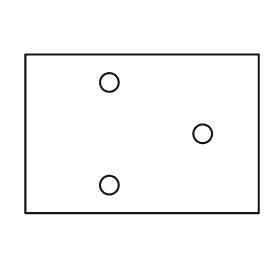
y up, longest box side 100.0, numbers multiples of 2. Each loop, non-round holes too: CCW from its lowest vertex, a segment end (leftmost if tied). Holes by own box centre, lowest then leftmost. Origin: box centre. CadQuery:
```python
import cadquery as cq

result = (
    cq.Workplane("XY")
    .moveTo(-50.0, -34.0)
    .lineTo(50.0, -34.0)
    .lineTo(50.0, 34.0)
    .lineTo(-50.0, 34.0)
    .close()
    .moveTo(-14.0, -22.0)
    .circle(4.0)
    .moveTo(26.0, 0.0)
    .circle(4.0)
    .moveTo(-14.0, 22.0)
    .circle(4.0)
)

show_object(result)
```